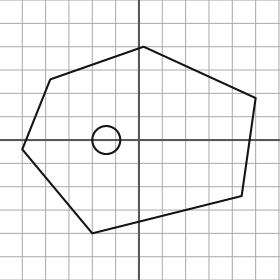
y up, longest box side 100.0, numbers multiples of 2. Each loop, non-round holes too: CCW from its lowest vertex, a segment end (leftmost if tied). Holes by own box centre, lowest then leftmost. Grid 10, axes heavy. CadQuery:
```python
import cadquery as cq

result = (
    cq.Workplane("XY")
    .moveTo(-20.0, -40.0)
    .lineTo(44.0, -24.0)
    .lineTo(50.0, 18.0)
    .lineTo(2.0, 40.0)
    .lineTo(-38.0, 26.0)
    .lineTo(-50.0, -4.0)
    .close()
    .moveTo(-14.0, 0.0)
    .circle(6.0)
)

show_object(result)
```